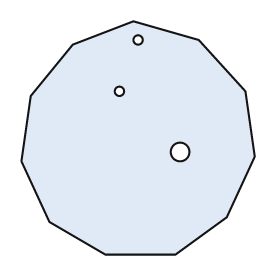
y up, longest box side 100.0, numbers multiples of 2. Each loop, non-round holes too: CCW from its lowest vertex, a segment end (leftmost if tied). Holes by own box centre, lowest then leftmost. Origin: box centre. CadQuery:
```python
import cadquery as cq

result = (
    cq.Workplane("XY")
    .moveTo(-14.0, -50.0)
    .lineTo(16.0, -50.0)
    .lineTo(38.0, -34.0)
    .lineTo(50.0, -8.0)
    .lineTo(46.0, 20.0)
    .lineTo(26.0, 42.0)
    .lineTo(-2.0, 50.0)
    .lineTo(-28.0, 40.0)
    .lineTo(-46.0, 18.0)
    .lineTo(-50.0, -10.0)
    .lineTo(-38.0, -36.0)
    .close()
    .moveTo(18.0, -6.0)
    .circle(4.0)
    .moveTo(-8.0, 20.0)
    .circle(2.0)
    .moveTo(0.0, 42.0)
    .circle(2.0)
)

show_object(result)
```